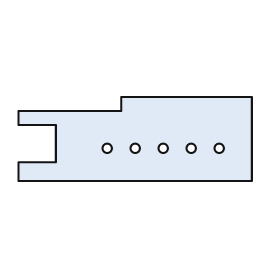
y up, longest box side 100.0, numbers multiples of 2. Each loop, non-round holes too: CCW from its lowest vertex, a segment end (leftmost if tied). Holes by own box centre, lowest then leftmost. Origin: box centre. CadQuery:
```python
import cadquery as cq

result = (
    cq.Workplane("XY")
    .moveTo(-50.0, -18.0)
    .lineTo(50.0, -18.0)
    .lineTo(50.0, 18.0)
    .lineTo(-6.0, 18.0)
    .lineTo(-6.0, 12.0)
    .lineTo(-50.0, 12.0)
    .lineTo(-50.0, 6.0)
    .lineTo(-34.0, 6.0)
    .lineTo(-34.0, -10.0)
    .lineTo(-50.0, -10.0)
    .close()
    .moveTo(-12.0, -4.0)
    .circle(2.0)
    .moveTo(0.0, -4.0)
    .circle(2.0)
    .moveTo(12.0, -4.0)
    .circle(2.0)
    .moveTo(24.0, -4.0)
    .circle(2.0)
    .moveTo(36.0, -4.0)
    .circle(2.0)
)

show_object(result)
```